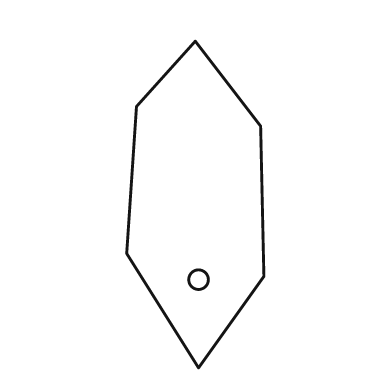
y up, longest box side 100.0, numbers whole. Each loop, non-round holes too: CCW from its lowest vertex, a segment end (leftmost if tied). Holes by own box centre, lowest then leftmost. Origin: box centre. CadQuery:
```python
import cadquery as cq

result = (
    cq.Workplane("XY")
    .moveTo(1.0, -50.0)
    .lineTo(21.0, -22.0)
    .lineTo(20.0, 24.0)
    .lineTo(0.0, 50.0)
    .lineTo(-18.0, 30.0)
    .lineTo(-21.0, -15.0)
    .close()
    .moveTo(1.0, -23.0)
    .circle(3.0)
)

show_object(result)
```